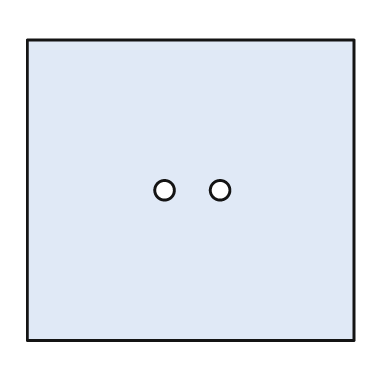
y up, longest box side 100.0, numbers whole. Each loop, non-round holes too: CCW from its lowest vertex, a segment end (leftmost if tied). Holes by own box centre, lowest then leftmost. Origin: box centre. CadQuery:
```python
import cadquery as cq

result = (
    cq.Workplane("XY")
    .moveTo(-50.0, -46.0)
    .lineTo(50.0, -46.0)
    .lineTo(50.0, 46.0)
    .lineTo(-50.0, 46.0)
    .close()
    .moveTo(-8.0, 0.0)
    .circle(3.0)
    .moveTo(9.0, 0.0)
    .circle(3.0)
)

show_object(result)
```